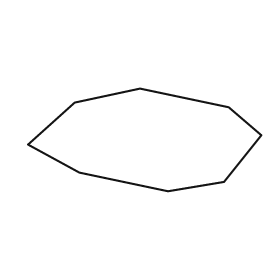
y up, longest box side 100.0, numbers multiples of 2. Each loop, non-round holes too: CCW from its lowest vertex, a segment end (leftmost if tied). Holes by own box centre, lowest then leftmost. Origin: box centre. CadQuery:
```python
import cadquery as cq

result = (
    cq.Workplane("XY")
    .moveTo(10.0, -22.0)
    .lineTo(34.0, -18.0)
    .lineTo(50.0, 2.0)
    .lineTo(36.0, 14.0)
    .lineTo(-2.0, 22.0)
    .lineTo(-30.0, 16.0)
    .lineTo(-50.0, -2.0)
    .lineTo(-28.0, -14.0)
    .close()
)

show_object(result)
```